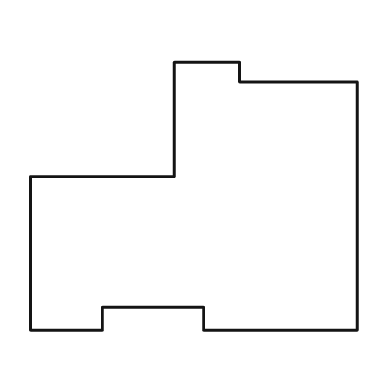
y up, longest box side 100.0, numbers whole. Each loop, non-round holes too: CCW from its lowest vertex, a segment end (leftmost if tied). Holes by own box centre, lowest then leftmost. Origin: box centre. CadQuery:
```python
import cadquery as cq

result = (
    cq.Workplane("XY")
    .moveTo(-50.0, -41.0)
    .lineTo(-28.0, -41.0)
    .lineTo(-28.0, -34.0)
    .lineTo(3.0, -34.0)
    .lineTo(3.0, -41.0)
    .lineTo(50.0, -41.0)
    .lineTo(50.0, 35.0)
    .lineTo(14.0, 35.0)
    .lineTo(14.0, 41.0)
    .lineTo(-6.0, 41.0)
    .lineTo(-6.0, 6.0)
    .lineTo(-50.0, 6.0)
    .close()
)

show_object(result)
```